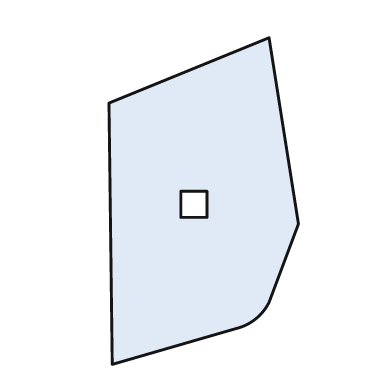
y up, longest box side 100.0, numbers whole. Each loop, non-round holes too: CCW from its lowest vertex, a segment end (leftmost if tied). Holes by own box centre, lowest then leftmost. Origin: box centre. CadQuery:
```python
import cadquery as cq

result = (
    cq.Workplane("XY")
    .moveTo(-28.0, -50.0)
    .lineTo(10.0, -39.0)
    .threePointArc((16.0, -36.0), (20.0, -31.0))
    .lineTo(29.0, -7.0)
    .lineTo(20.0, 50.0)
    .lineTo(-29.0, 30.0)
    .close()
    .moveTo(-7.0, -5.0)
    .lineTo(1.0, -5.0)
    .lineTo(1.0, 3.0)
    .lineTo(-7.0, 3.0)
    .close()
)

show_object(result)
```